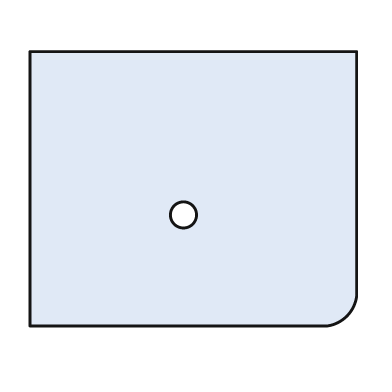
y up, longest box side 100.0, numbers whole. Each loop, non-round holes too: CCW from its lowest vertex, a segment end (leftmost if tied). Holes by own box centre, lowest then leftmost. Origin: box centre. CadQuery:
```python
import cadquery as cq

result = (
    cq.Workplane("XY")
    .moveTo(-50.0, -42.0)
    .lineTo(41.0, -42.0)
    .threePointArc((47.0, -39.0), (50.0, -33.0))
    .lineTo(50.0, 42.0)
    .lineTo(-50.0, 42.0)
    .close()
    .moveTo(-3.0, -8.0)
    .circle(4.0)
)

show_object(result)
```